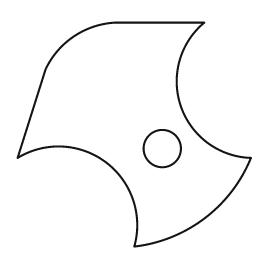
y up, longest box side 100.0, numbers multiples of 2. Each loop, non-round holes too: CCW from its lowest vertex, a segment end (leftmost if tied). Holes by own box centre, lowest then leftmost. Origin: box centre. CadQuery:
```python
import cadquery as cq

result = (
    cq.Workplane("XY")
    .moveTo(0.0, -48.0)
    .threePointArc((30.0, -36.0), (50.0, -10.0))
    .threePointArc((20.0, 12.0), (30.0, 48.0))
    .lineTo(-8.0, 48.0)
    .threePointArc((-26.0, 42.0), (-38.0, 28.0))
    .lineTo(-50.0, -10.0)
    .threePointArc((-12.0, -12.0), (0.0, -48.0))
    .close()
    .moveTo(12.0, -6.0)
    .circle(8.0)
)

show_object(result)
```